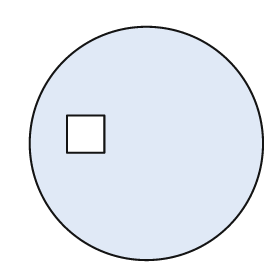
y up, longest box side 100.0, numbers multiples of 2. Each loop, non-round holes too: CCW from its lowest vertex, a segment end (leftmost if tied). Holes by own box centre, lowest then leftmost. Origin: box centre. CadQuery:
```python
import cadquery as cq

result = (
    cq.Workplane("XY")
    .moveTo(0.0, 0.0)
    .circle(50.0)
    .moveTo(-34.0, -4.0)
    .lineTo(-18.0, -4.0)
    .lineTo(-18.0, 12.0)
    .lineTo(-34.0, 12.0)
    .close()
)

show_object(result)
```